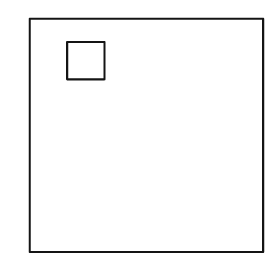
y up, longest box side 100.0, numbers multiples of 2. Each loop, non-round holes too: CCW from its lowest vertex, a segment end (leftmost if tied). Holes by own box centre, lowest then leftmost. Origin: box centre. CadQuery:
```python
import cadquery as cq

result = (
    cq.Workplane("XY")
    .moveTo(-50.0, -50.0)
    .lineTo(50.0, -50.0)
    .lineTo(50.0, 50.0)
    .lineTo(-50.0, 50.0)
    .close()
    .moveTo(-34.0, 24.0)
    .lineTo(-18.0, 24.0)
    .lineTo(-18.0, 40.0)
    .lineTo(-34.0, 40.0)
    .close()
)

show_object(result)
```